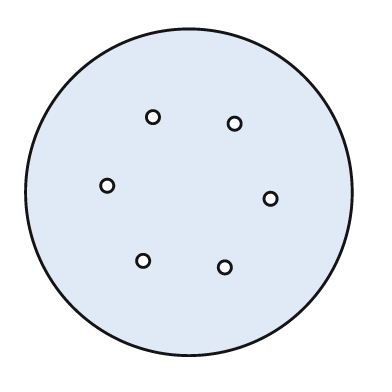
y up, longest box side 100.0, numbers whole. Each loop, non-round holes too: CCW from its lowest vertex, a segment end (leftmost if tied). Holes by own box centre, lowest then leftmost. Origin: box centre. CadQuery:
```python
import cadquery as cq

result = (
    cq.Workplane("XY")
    .moveTo(0.0, 0.0)
    .circle(50.0)
    .moveTo(11.0, -23.0)
    .circle(2.0)
    .moveTo(-14.0, -21.0)
    .circle(2.0)
    .moveTo(25.0, -2.0)
    .circle(2.0)
    .moveTo(-25.0, 2.0)
    .circle(2.0)
    .moveTo(14.0, 21.0)
    .circle(2.0)
    .moveTo(-11.0, 23.0)
    .circle(2.0)
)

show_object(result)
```